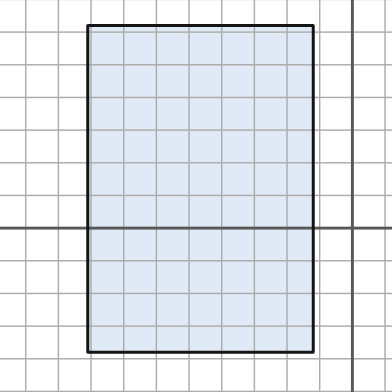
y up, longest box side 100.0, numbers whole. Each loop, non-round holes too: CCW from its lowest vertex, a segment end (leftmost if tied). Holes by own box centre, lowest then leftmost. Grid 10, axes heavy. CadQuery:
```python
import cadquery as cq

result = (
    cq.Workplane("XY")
    .moveTo(-81.0, -38.0)
    .lineTo(-12.0, -38.0)
    .lineTo(-12.0, 62.0)
    .lineTo(-81.0, 62.0)
    .close()
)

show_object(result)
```